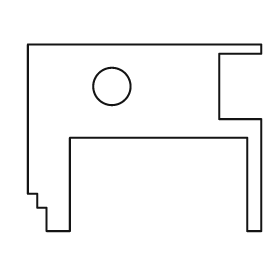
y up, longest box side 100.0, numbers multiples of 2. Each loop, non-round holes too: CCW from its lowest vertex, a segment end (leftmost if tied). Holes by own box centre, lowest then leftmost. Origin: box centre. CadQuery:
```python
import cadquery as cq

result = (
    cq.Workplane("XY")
    .moveTo(-42.0, -40.0)
    .lineTo(-32.0, -40.0)
    .lineTo(-32.0, 0.0)
    .lineTo(44.0, 0.0)
    .lineTo(44.0, -40.0)
    .lineTo(50.0, -40.0)
    .lineTo(50.0, 8.0)
    .lineTo(32.0, 8.0)
    .lineTo(32.0, 36.0)
    .lineTo(50.0, 36.0)
    .lineTo(50.0, 40.0)
    .lineTo(-50.0, 40.0)
    .lineTo(-50.0, -24.0)
    .lineTo(-46.0, -24.0)
    .lineTo(-46.0, -30.0)
    .lineTo(-42.0, -30.0)
    .close()
    .moveTo(-14.0, 22.0)
    .circle(8.0)
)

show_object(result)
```